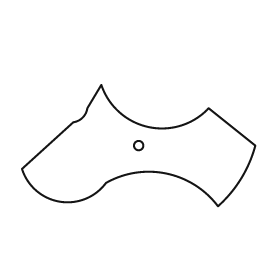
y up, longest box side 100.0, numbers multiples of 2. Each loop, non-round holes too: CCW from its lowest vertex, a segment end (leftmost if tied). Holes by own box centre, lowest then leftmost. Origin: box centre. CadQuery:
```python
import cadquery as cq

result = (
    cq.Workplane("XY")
    .moveTo(34.0, -26.0)
    .threePointArc((44.0, -14.0), (50.0, 0.0))
    .lineTo(30.0, 16.0)
    .threePointArc((4.0, 8.0), (-16.0, 26.0))
    .lineTo(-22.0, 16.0)
    .threePointArc((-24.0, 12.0), (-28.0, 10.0))
    .lineTo(-50.0, -10.0)
    .threePointArc((-34.0, -24.0), (-14.0, -16.0))
    .threePointArc((12.0, -12.0), (34.0, -26.0))
    .close()
    .moveTo(0.0, 0.0)
    .circle(2.0)
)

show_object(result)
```